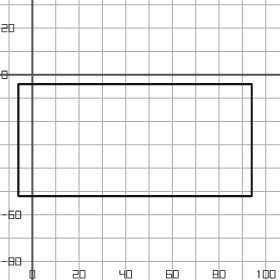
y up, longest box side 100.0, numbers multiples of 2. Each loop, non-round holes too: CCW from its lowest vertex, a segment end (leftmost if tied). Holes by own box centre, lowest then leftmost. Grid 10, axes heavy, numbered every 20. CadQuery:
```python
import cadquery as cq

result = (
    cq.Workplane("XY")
    .moveTo(-6.0, -52.0)
    .lineTo(94.0, -52.0)
    .lineTo(94.0, -4.0)
    .lineTo(-6.0, -4.0)
    .close()
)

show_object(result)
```